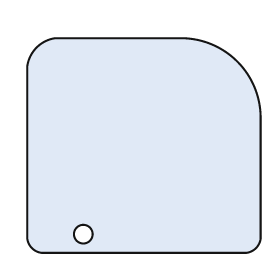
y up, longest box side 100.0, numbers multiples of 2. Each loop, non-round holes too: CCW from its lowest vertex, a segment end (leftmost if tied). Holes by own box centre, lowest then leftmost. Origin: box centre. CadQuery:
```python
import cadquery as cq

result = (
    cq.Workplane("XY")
    .moveTo(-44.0, -46.0)
    .lineTo(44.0, -46.0)
    .threePointArc((48.0, -44.0), (50.0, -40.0))
    .lineTo(50.0, 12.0)
    .threePointArc((40.0, 36.0), (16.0, 46.0))
    .lineTo(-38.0, 46.0)
    .threePointArc((-46.0, 42.0), (-50.0, 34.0))
    .lineTo(-50.0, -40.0)
    .threePointArc((-48.0, -44.0), (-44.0, -46.0))
    .close()
    .moveTo(-26.0, -38.0)
    .circle(4.0)
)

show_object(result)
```